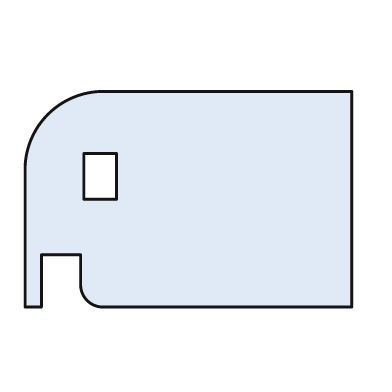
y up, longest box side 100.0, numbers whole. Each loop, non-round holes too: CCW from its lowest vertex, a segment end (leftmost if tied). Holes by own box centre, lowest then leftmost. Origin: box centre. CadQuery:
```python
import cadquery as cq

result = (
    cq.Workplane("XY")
    .moveTo(-50.0, -33.0)
    .lineTo(-45.0, -33.0)
    .lineTo(-45.0, -17.0)
    .lineTo(-33.0, -17.0)
    .lineTo(-33.0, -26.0)
    .threePointArc((-31.0, -31.0), (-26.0, -33.0))
    .lineTo(50.0, -33.0)
    .lineTo(50.0, 33.0)
    .lineTo(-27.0, 33.0)
    .threePointArc((-43.0, 26.0), (-50.0, 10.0))
    .close()
    .moveTo(-32.0, 0.0)
    .lineTo(-22.0, 0.0)
    .lineTo(-22.0, 14.0)
    .lineTo(-32.0, 14.0)
    .close()
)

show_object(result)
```